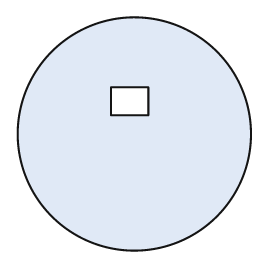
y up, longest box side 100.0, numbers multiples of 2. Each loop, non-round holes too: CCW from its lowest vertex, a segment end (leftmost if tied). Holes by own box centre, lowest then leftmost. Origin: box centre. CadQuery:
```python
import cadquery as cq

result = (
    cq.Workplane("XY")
    .moveTo(0.0, 0.0)
    .circle(50.0)
    .moveTo(-10.0, 8.0)
    .lineTo(6.0, 8.0)
    .lineTo(6.0, 20.0)
    .lineTo(-10.0, 20.0)
    .close()
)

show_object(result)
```